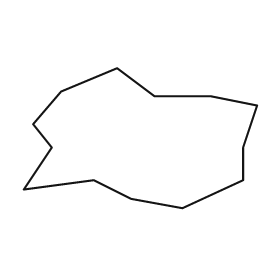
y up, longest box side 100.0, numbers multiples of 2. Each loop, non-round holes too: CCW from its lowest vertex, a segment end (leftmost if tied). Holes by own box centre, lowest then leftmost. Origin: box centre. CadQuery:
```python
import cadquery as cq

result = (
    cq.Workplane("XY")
    .moveTo(18.0, -30.0)
    .lineTo(44.0, -18.0)
    .lineTo(44.0, -4.0)
    .lineTo(50.0, 14.0)
    .lineTo(30.0, 18.0)
    .lineTo(6.0, 18.0)
    .lineTo(-10.0, 30.0)
    .lineTo(-34.0, 20.0)
    .lineTo(-46.0, 6.0)
    .lineTo(-38.0, -4.0)
    .lineTo(-50.0, -22.0)
    .lineTo(-20.0, -18.0)
    .lineTo(-4.0, -26.0)
    .close()
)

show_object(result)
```